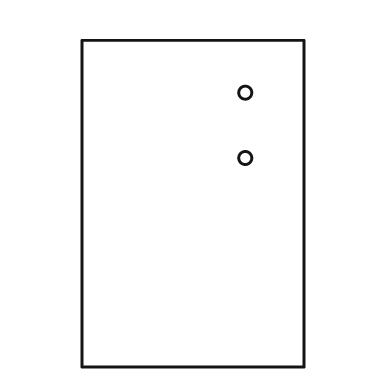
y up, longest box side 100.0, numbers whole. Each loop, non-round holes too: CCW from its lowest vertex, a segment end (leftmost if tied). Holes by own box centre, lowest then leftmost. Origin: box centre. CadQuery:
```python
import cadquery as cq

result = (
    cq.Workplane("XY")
    .moveTo(-34.0, -50.0)
    .lineTo(34.0, -50.0)
    .lineTo(34.0, 50.0)
    .lineTo(-34.0, 50.0)
    .close()
    .moveTo(16.0, 14.0)
    .circle(2.0)
    .moveTo(16.0, 34.0)
    .circle(2.0)
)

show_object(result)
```